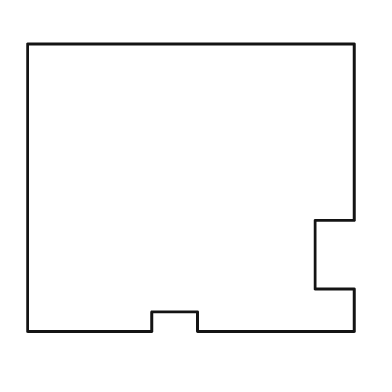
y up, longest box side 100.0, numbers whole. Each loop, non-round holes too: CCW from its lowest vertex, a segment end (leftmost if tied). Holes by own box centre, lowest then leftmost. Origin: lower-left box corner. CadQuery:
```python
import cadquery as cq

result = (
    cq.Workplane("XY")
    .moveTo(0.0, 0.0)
    .lineTo(38.0, 0.0)
    .lineTo(38.0, 6.0)
    .lineTo(52.0, 6.0)
    .lineTo(52.0, 0.0)
    .lineTo(100.0, 0.0)
    .lineTo(100.0, 13.0)
    .lineTo(88.0, 13.0)
    .lineTo(88.0, 34.0)
    .lineTo(100.0, 34.0)
    .lineTo(100.0, 88.0)
    .lineTo(0.0, 88.0)
    .close()
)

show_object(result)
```